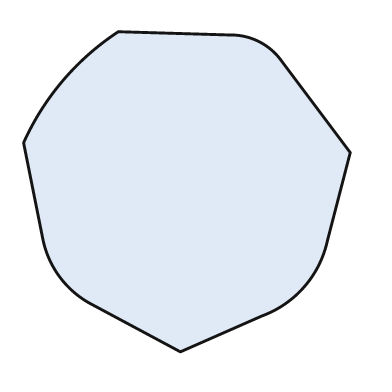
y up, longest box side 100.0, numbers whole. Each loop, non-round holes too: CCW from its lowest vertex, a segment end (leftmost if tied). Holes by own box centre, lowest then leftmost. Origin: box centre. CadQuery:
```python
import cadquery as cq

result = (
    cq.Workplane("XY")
    .moveTo(-2.0, -49.0)
    .lineTo(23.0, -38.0)
    .threePointArc((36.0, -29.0), (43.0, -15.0))
    .lineTo(50.0, 12.0)
    .lineTo(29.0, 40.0)
    .threePointArc((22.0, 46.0), (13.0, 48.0))
    .lineTo(-21.0, 49.0)
    .threePointArc((-38.0, 34.0), (-50.0, 15.0))
    .lineTo(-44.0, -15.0)
    .threePointArc((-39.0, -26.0), (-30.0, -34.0))
    .close()
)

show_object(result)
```